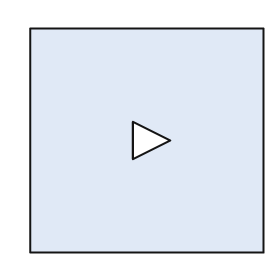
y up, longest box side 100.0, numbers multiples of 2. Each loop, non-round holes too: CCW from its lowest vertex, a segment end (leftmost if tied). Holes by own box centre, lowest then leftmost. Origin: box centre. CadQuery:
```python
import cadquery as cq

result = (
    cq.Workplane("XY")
    .moveTo(-50.0, -48.0)
    .lineTo(50.0, -48.0)
    .lineTo(50.0, 48.0)
    .lineTo(-50.0, 48.0)
    .close()
    .moveTo(-6.0, -8.0)
    .lineTo(10.0, 0.0)
    .lineTo(-6.0, 8.0)
    .close()
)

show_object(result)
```